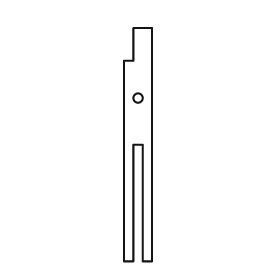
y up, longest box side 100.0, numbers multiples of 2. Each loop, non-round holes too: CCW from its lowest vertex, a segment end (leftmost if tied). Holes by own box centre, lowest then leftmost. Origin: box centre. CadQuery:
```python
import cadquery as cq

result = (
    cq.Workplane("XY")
    .moveTo(-6.0, -50.0)
    .lineTo(-2.0, -50.0)
    .lineTo(-2.0, 0.0)
    .lineTo(2.0, 0.0)
    .lineTo(2.0, -50.0)
    .lineTo(6.0, -50.0)
    .lineTo(6.0, 50.0)
    .lineTo(-2.0, 50.0)
    .lineTo(-2.0, 36.0)
    .lineTo(-6.0, 36.0)
    .close()
    .moveTo(0.0, 20.0)
    .circle(2.0)
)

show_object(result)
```